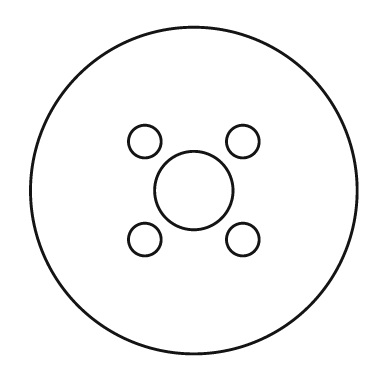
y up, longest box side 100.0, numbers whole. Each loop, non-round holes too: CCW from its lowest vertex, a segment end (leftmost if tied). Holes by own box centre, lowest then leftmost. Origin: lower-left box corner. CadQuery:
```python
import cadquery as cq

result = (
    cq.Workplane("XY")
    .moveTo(50.0, 50.0)
    .circle(50.0)
    .moveTo(35.0, 35.0)
    .circle(5.0)
    .moveTo(65.0, 35.0)
    .circle(5.0)
    .moveTo(50.0, 50.0)
    .circle(12.0)
    .moveTo(35.0, 65.0)
    .circle(5.0)
    .moveTo(65.0, 65.0)
    .circle(5.0)
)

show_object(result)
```